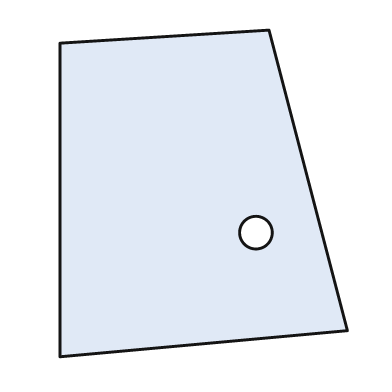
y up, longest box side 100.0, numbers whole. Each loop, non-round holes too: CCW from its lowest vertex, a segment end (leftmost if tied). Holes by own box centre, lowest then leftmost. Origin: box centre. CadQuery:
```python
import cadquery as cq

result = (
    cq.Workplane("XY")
    .moveTo(-44.0, -50.0)
    .lineTo(44.0, -42.0)
    .lineTo(20.0, 50.0)
    .lineTo(-44.0, 46.0)
    .close()
    .moveTo(16.0, -12.0)
    .circle(5.0)
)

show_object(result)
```